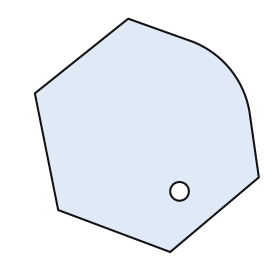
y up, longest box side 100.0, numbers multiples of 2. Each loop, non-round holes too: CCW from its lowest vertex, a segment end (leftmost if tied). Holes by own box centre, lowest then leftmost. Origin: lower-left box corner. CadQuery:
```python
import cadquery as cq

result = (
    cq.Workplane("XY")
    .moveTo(58.0, 0.0)
    .lineTo(96.0, 32.0)
    .lineTo(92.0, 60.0)
    .threePointArc((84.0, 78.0), (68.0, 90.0))
    .lineTo(40.0, 100.0)
    .lineTo(0.0, 68.0)
    .lineTo(10.0, 18.0)
    .close()
    .moveTo(62.0, 26.0)
    .circle(4.0)
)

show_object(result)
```